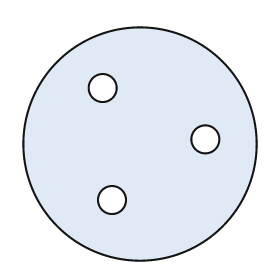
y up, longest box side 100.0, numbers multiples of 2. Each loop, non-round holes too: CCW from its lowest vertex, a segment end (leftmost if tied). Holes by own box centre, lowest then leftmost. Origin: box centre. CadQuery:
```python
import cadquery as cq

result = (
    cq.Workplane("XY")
    .moveTo(0.0, 0.0)
    .circle(50.0)
    .moveTo(-12.0, -24.0)
    .circle(6.0)
    .moveTo(28.0, 2.0)
    .circle(6.0)
    .moveTo(-16.0, 24.0)
    .circle(6.0)
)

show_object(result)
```